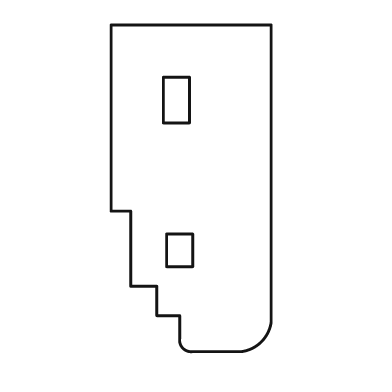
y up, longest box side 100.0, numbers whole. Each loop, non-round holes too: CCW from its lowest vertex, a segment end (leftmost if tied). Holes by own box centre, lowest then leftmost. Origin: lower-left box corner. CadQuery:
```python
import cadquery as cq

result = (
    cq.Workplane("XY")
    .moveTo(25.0, 0.0)
    .lineTo(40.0, 0.0)
    .threePointArc((46.0, 3.0), (49.0, 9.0))
    .lineTo(49.0, 100.0)
    .lineTo(0.0, 100.0)
    .lineTo(0.0, 43.0)
    .lineTo(6.0, 43.0)
    .lineTo(6.0, 20.0)
    .lineTo(14.0, 20.0)
    .lineTo(14.0, 11.0)
    .lineTo(21.0, 11.0)
    .lineTo(21.0, 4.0)
    .threePointArc((22.0, 1.0), (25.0, 0.0))
    .close()
    .moveTo(17.0, 26.0)
    .lineTo(25.0, 26.0)
    .lineTo(25.0, 36.0)
    .lineTo(17.0, 36.0)
    .close()
    .moveTo(16.0, 70.0)
    .lineTo(24.0, 70.0)
    .lineTo(24.0, 84.0)
    .lineTo(16.0, 84.0)
    .close()
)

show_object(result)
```